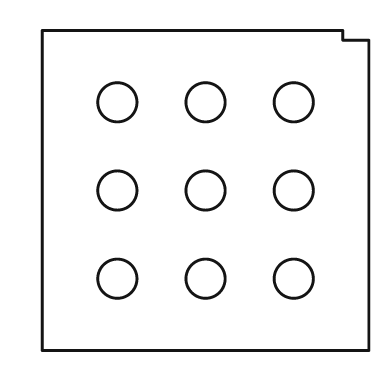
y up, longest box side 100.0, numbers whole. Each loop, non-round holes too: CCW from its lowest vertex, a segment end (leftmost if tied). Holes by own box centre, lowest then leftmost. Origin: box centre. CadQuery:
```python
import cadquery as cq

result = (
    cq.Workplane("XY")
    .moveTo(-50.0, -49.0)
    .lineTo(50.0, -49.0)
    .lineTo(50.0, 46.0)
    .lineTo(42.0, 46.0)
    .lineTo(42.0, 49.0)
    .lineTo(-50.0, 49.0)
    .close()
    .moveTo(-27.0, -27.0)
    .circle(6.0)
    .moveTo(0.0, -27.0)
    .circle(6.0)
    .moveTo(27.0, -27.0)
    .circle(6.0)
    .moveTo(-27.0, 0.0)
    .circle(6.0)
    .moveTo(0.0, 0.0)
    .circle(6.0)
    .moveTo(27.0, 0.0)
    .circle(6.0)
    .moveTo(-27.0, 27.0)
    .circle(6.0)
    .moveTo(0.0, 27.0)
    .circle(6.0)
    .moveTo(27.0, 27.0)
    .circle(6.0)
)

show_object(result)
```